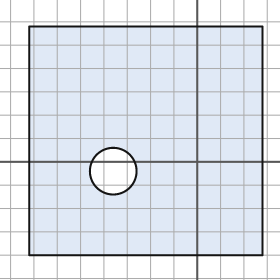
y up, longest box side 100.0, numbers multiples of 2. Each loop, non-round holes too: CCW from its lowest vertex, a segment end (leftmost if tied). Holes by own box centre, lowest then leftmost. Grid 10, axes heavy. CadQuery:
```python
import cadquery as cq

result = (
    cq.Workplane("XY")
    .moveTo(-72.0, -40.0)
    .lineTo(28.0, -40.0)
    .lineTo(28.0, 58.0)
    .lineTo(-72.0, 58.0)
    .close()
    .moveTo(-36.0, -4.0)
    .circle(10.0)
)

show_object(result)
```